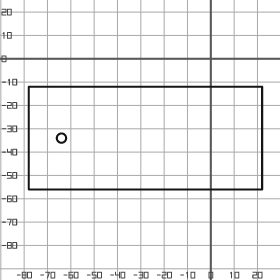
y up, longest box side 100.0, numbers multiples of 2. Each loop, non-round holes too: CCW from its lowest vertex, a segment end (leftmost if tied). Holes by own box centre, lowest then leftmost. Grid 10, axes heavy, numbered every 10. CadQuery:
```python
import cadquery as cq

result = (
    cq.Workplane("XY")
    .moveTo(-78.0, -56.0)
    .lineTo(22.0, -56.0)
    .lineTo(22.0, -12.0)
    .lineTo(-78.0, -12.0)
    .close()
    .moveTo(-64.0, -34.0)
    .circle(2.0)
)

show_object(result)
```